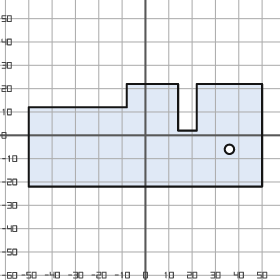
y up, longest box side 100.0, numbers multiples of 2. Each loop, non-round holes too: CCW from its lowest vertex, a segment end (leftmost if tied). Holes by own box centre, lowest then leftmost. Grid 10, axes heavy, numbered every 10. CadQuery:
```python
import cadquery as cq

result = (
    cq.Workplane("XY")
    .moveTo(-50.0, -22.0)
    .lineTo(50.0, -22.0)
    .lineTo(50.0, 22.0)
    .lineTo(22.0, 22.0)
    .lineTo(22.0, 2.0)
    .lineTo(14.0, 2.0)
    .lineTo(14.0, 22.0)
    .lineTo(-8.0, 22.0)
    .lineTo(-8.0, 12.0)
    .lineTo(-50.0, 12.0)
    .close()
    .moveTo(36.0, -6.0)
    .circle(2.0)
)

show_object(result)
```